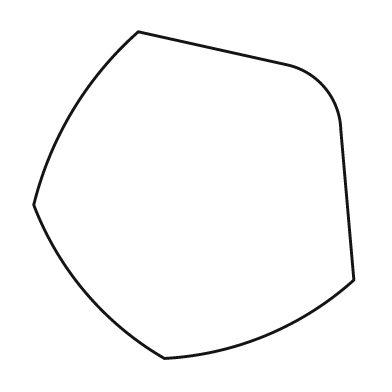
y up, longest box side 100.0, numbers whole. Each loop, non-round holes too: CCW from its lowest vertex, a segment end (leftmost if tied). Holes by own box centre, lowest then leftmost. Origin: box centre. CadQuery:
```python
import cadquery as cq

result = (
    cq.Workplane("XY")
    .moveTo(-9.0, -50.0)
    .threePointArc((22.0, -43.0), (49.0, -26.0))
    .lineTo(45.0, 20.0)
    .threePointArc((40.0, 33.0), (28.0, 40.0))
    .lineTo(-17.0, 50.0)
    .threePointArc((-37.0, 26.0), (-49.0, -3.0))
    .threePointArc((-33.0, -30.0), (-9.0, -50.0))
    .close()
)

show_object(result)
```